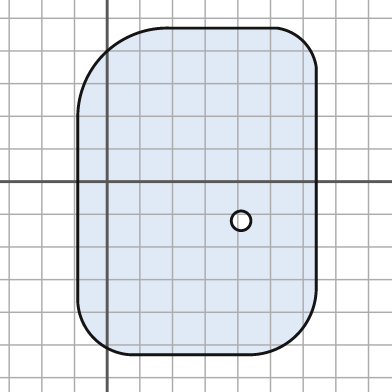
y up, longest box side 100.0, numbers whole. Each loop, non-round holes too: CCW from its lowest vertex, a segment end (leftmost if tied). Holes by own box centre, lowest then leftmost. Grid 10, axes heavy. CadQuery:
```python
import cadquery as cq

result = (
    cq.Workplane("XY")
    .moveTo(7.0, -53.0)
    .lineTo(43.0, -53.0)
    .threePointArc((58.0, -47.0), (64.0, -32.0))
    .lineTo(64.0, 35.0)
    .threePointArc((60.0, 43.0), (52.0, 47.0))
    .lineTo(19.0, 47.0)
    .threePointArc((-1.0, 39.0), (-9.0, 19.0))
    .lineTo(-9.0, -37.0)
    .threePointArc((-4.0, -48.0), (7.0, -53.0))
    .close()
    .moveTo(41.0, -12.0)
    .circle(3.0)
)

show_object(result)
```